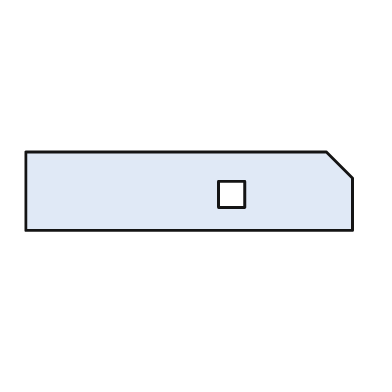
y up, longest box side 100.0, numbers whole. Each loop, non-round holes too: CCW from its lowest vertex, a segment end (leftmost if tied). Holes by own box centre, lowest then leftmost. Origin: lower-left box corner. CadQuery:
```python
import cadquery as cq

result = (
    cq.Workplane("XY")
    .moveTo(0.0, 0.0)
    .lineTo(100.0, 0.0)
    .lineTo(100.0, 16.0)
    .lineTo(92.0, 24.0)
    .lineTo(0.0, 24.0)
    .close()
    .moveTo(59.0, 7.0)
    .lineTo(67.0, 7.0)
    .lineTo(67.0, 15.0)
    .lineTo(59.0, 15.0)
    .close()
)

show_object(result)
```